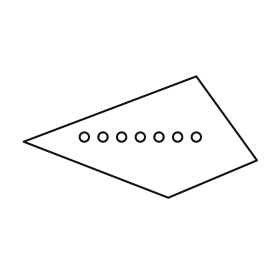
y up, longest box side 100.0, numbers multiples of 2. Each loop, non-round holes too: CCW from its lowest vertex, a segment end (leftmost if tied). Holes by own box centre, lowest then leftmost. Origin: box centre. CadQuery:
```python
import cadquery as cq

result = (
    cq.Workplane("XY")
    .moveTo(12.0, -26.0)
    .lineTo(50.0, -10.0)
    .lineTo(24.0, 26.0)
    .lineTo(-50.0, -2.0)
    .close()
    .moveTo(-24.0, 0.0)
    .circle(2.0)
    .moveTo(-16.0, 0.0)
    .circle(2.0)
    .moveTo(-8.0, 0.0)
    .circle(2.0)
    .moveTo(0.0, 0.0)
    .circle(2.0)
    .moveTo(8.0, 0.0)
    .circle(2.0)
    .moveTo(16.0, 0.0)
    .circle(2.0)
    .moveTo(24.0, 0.0)
    .circle(2.0)
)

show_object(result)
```